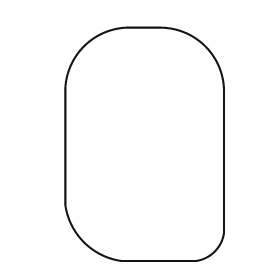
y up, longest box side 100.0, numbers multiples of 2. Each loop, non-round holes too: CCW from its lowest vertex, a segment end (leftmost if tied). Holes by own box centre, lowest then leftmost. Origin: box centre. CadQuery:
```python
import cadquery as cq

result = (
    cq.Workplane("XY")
    .moveTo(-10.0, -50.0)
    .lineTo(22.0, -50.0)
    .threePointArc((30.0, -46.0), (34.0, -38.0))
    .lineTo(34.0, 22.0)
    .threePointArc((26.0, 42.0), (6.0, 50.0))
    .lineTo(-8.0, 50.0)
    .threePointArc((-26.0, 42.0), (-34.0, 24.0))
    .lineTo(-34.0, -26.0)
    .threePointArc((-26.0, -42.0), (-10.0, -50.0))
    .close()
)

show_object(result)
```